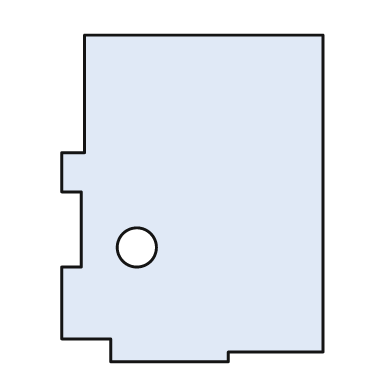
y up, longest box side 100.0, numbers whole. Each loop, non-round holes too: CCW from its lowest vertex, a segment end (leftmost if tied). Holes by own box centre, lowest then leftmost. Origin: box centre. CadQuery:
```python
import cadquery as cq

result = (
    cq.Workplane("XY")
    .moveTo(-25.0, -50.0)
    .lineTo(11.0, -50.0)
    .lineTo(11.0, -47.0)
    .lineTo(40.0, -47.0)
    .lineTo(40.0, 50.0)
    .lineTo(-33.0, 50.0)
    .lineTo(-33.0, 14.0)
    .lineTo(-40.0, 14.0)
    .lineTo(-40.0, 2.0)
    .lineTo(-34.0, 2.0)
    .lineTo(-34.0, -21.0)
    .lineTo(-40.0, -21.0)
    .lineTo(-40.0, -43.0)
    .lineTo(-25.0, -43.0)
    .close()
    .moveTo(-17.0, -15.0)
    .circle(6.0)
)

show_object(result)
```